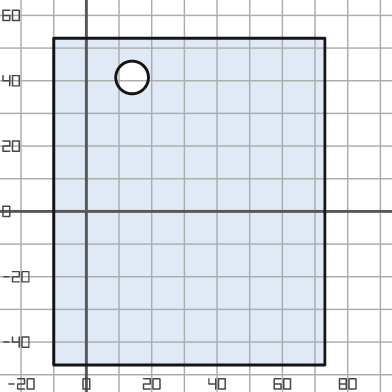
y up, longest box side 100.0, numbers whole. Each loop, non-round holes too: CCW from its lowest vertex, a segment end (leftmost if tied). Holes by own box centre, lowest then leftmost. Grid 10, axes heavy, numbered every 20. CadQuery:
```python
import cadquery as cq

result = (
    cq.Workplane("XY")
    .moveTo(-10.0, -47.0)
    .lineTo(73.0, -47.0)
    .lineTo(73.0, 53.0)
    .lineTo(-10.0, 53.0)
    .close()
    .moveTo(14.0, 41.0)
    .circle(5.0)
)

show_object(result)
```